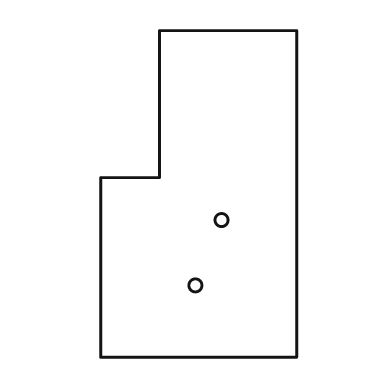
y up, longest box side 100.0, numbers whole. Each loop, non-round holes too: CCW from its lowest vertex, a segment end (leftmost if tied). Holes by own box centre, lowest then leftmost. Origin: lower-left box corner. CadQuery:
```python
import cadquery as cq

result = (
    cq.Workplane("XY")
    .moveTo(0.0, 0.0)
    .lineTo(60.0, 0.0)
    .lineTo(60.0, 100.0)
    .lineTo(18.0, 100.0)
    .lineTo(18.0, 55.0)
    .lineTo(0.0, 55.0)
    .close()
    .moveTo(29.0, 22.0)
    .circle(2.0)
    .moveTo(37.0, 42.0)
    .circle(2.0)
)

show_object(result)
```